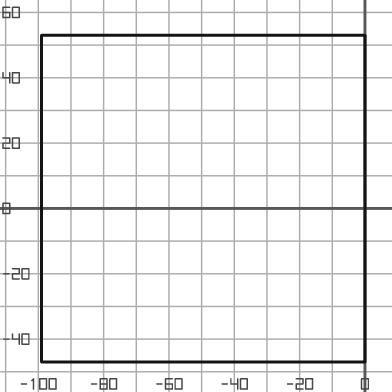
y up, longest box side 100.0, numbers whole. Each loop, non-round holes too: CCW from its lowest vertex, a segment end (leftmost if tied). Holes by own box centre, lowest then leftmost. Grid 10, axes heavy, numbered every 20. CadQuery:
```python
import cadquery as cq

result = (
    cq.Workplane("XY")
    .moveTo(-99.0, -47.0)
    .lineTo(0.0, -47.0)
    .lineTo(0.0, 53.0)
    .lineTo(-99.0, 53.0)
    .close()
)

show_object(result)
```